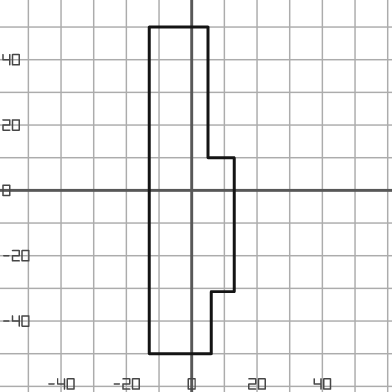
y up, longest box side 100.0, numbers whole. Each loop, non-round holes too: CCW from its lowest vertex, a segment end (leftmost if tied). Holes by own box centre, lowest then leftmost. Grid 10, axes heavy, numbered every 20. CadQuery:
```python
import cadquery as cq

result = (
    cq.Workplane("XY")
    .moveTo(-13.0, -50.0)
    .lineTo(6.0, -50.0)
    .lineTo(6.0, -31.0)
    .lineTo(13.0, -31.0)
    .lineTo(13.0, 10.0)
    .lineTo(5.0, 10.0)
    .lineTo(5.0, 50.0)
    .lineTo(-13.0, 50.0)
    .close()
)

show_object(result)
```